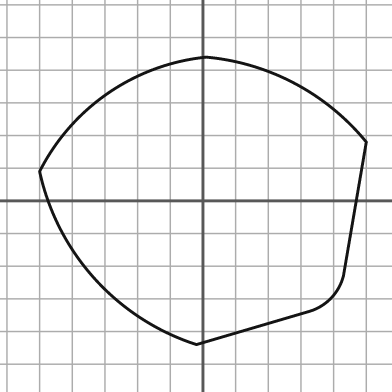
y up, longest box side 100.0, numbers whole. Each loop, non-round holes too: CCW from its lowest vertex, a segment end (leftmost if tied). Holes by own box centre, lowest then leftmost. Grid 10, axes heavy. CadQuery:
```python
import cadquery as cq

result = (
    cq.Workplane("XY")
    .moveTo(-2.0, -44.0)
    .lineTo(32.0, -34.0)
    .threePointArc((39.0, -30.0), (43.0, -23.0))
    .lineTo(50.0, 18.0)
    .threePointArc((28.0, 36.0), (1.0, 44.0))
    .threePointArc((-29.0, 33.0), (-50.0, 9.0))
    .threePointArc((-33.0, -24.0), (-2.0, -44.0))
    .close()
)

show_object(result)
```